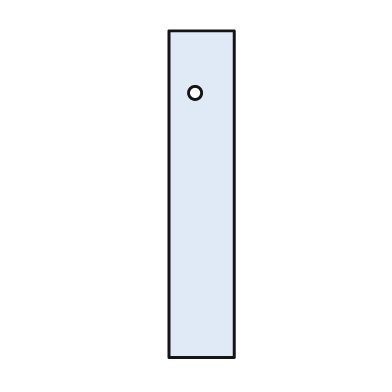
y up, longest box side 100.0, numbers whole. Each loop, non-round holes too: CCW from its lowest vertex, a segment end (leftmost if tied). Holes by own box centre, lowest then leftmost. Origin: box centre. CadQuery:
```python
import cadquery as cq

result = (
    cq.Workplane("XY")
    .moveTo(-10.0, -50.0)
    .lineTo(10.0, -50.0)
    .lineTo(10.0, 50.0)
    .lineTo(-10.0, 50.0)
    .close()
    .moveTo(-2.0, 31.0)
    .circle(2.0)
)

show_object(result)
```